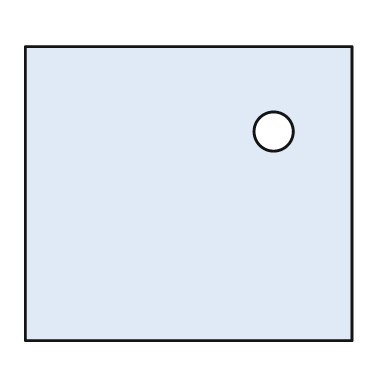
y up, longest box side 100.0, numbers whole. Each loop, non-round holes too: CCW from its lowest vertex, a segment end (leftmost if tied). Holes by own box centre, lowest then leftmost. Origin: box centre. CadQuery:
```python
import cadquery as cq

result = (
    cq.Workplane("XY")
    .moveTo(-50.0, -45.0)
    .lineTo(50.0, -45.0)
    .lineTo(50.0, 45.0)
    .lineTo(-50.0, 45.0)
    .close()
    .moveTo(26.0, 19.0)
    .circle(6.0)
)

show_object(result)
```